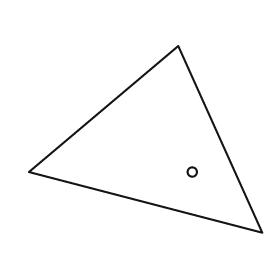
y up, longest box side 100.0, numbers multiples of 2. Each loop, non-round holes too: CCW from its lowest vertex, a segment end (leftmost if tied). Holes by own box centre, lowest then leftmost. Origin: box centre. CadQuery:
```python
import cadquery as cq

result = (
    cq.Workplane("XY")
    .moveTo(50.0, -40.0)
    .lineTo(14.0, 40.0)
    .lineTo(-50.0, -14.0)
    .close()
    .moveTo(20.0, -14.0)
    .circle(2.0)
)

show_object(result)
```